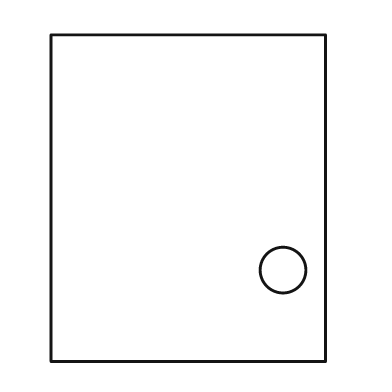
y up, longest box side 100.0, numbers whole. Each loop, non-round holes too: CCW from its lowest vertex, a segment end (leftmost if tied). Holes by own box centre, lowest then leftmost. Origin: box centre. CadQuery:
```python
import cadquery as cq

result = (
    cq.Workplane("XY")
    .moveTo(-42.0, -50.0)
    .lineTo(42.0, -50.0)
    .lineTo(42.0, 50.0)
    .lineTo(-42.0, 50.0)
    .close()
    .moveTo(29.0, -22.0)
    .circle(7.0)
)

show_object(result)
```